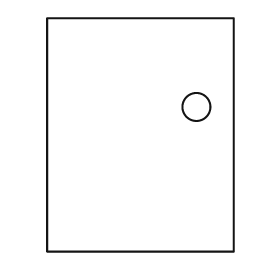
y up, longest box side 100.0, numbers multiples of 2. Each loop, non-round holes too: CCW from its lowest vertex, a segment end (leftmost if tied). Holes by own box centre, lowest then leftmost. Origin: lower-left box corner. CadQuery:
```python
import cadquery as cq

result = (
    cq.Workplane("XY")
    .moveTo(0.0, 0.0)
    .lineTo(80.0, 0.0)
    .lineTo(80.0, 100.0)
    .lineTo(0.0, 100.0)
    .close()
    .moveTo(64.0, 62.0)
    .circle(6.0)
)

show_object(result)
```